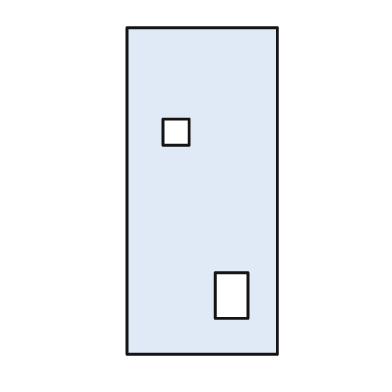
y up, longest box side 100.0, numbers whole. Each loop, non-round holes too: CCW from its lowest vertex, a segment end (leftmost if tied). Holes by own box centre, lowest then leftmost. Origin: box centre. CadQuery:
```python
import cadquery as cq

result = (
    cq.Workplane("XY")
    .moveTo(-23.0, -50.0)
    .lineTo(23.0, -50.0)
    .lineTo(23.0, 50.0)
    .lineTo(-23.0, 50.0)
    .close()
    .moveTo(4.0, -39.0)
    .lineTo(14.0, -39.0)
    .lineTo(14.0, -25.0)
    .lineTo(4.0, -25.0)
    .close()
    .moveTo(-12.0, 14.0)
    .lineTo(-4.0, 14.0)
    .lineTo(-4.0, 22.0)
    .lineTo(-12.0, 22.0)
    .close()
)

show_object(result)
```